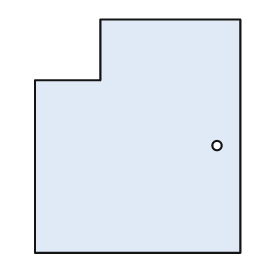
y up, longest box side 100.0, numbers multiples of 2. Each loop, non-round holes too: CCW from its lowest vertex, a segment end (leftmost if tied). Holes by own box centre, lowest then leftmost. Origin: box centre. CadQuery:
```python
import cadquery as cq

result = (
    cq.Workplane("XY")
    .moveTo(-44.0, -50.0)
    .lineTo(44.0, -50.0)
    .lineTo(44.0, 50.0)
    .lineTo(-16.0, 50.0)
    .lineTo(-16.0, 24.0)
    .lineTo(-44.0, 24.0)
    .close()
    .moveTo(34.0, -4.0)
    .circle(2.0)
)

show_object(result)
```